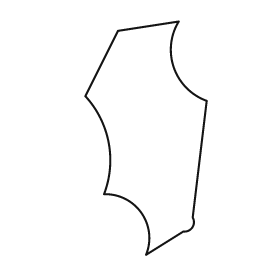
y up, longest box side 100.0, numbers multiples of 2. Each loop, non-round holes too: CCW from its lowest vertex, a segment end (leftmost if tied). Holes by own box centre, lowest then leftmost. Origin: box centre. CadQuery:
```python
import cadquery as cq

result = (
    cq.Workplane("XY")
    .moveTo(0.0, -50.0)
    .lineTo(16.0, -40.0)
    .threePointArc((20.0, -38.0), (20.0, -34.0))
    .lineTo(26.0, 16.0)
    .threePointArc((12.0, 30.0), (14.0, 50.0))
    .lineTo(-12.0, 46.0)
    .lineTo(-26.0, 18.0)
    .threePointArc((-16.0, -2.0), (-18.0, -24.0))
    .threePointArc((-2.0, -32.0), (0.0, -50.0))
    .close()
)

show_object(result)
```